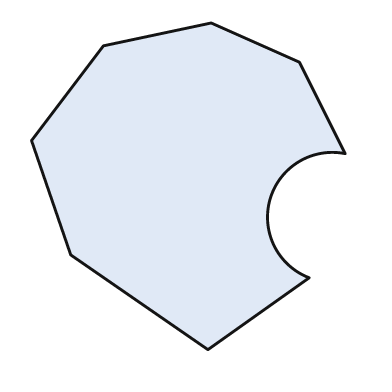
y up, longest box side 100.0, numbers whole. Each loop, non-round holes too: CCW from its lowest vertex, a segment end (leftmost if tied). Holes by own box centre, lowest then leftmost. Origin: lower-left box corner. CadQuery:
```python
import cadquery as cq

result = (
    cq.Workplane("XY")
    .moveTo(54.0, 0.0)
    .lineTo(85.0, 22.0)
    .threePointArc((73.0, 46.0), (96.0, 60.0))
    .lineTo(82.0, 88.0)
    .lineTo(55.0, 100.0)
    .lineTo(22.0, 93.0)
    .lineTo(0.0, 64.0)
    .lineTo(12.0, 29.0)
    .close()
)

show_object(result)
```